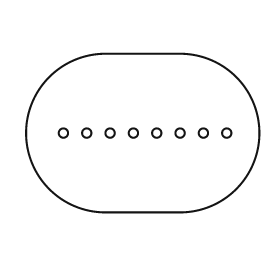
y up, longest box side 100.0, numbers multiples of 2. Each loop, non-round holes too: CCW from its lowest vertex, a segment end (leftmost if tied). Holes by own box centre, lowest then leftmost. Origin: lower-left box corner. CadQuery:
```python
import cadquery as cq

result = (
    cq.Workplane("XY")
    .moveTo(34.0, 0.0)
    .lineTo(66.0, 0.0)
    .threePointArc((100.0, 34.0), (66.0, 68.0))
    .lineTo(34.0, 68.0)
    .threePointArc((0.0, 34.0), (34.0, 0.0))
    .close()
    .moveTo(16.0, 34.0)
    .circle(2.0)
    .moveTo(26.0, 34.0)
    .circle(2.0)
    .moveTo(36.0, 34.0)
    .circle(2.0)
    .moveTo(46.0, 34.0)
    .circle(2.0)
    .moveTo(56.0, 34.0)
    .circle(2.0)
    .moveTo(66.0, 34.0)
    .circle(2.0)
    .moveTo(76.0, 34.0)
    .circle(2.0)
    .moveTo(86.0, 34.0)
    .circle(2.0)
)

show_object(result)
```